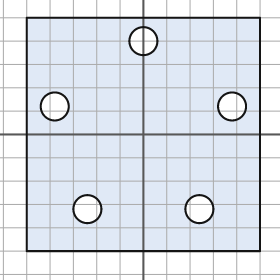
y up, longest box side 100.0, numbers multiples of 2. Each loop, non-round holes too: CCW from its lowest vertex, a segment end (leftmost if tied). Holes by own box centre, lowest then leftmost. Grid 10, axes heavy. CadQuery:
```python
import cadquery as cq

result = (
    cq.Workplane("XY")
    .moveTo(-50.0, -50.0)
    .lineTo(50.0, -50.0)
    .lineTo(50.0, 50.0)
    .lineTo(-50.0, 50.0)
    .close()
    .moveTo(-24.0, -32.0)
    .circle(6.0)
    .moveTo(24.0, -32.0)
    .circle(6.0)
    .moveTo(-38.0, 12.0)
    .circle(6.0)
    .moveTo(38.0, 12.0)
    .circle(6.0)
    .moveTo(0.0, 40.0)
    .circle(6.0)
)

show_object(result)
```